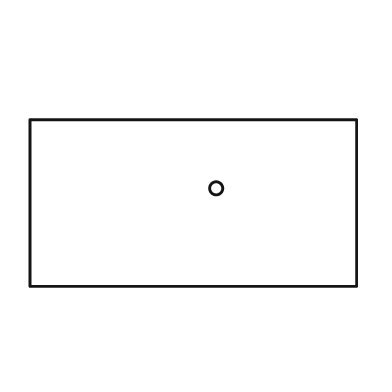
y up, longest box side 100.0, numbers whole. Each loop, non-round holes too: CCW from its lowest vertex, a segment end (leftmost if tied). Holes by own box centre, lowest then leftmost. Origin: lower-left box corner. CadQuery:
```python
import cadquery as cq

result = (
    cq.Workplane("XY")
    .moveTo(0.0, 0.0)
    .lineTo(100.0, 0.0)
    .lineTo(100.0, 51.0)
    .lineTo(0.0, 51.0)
    .close()
    .moveTo(57.0, 30.0)
    .circle(2.0)
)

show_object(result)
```